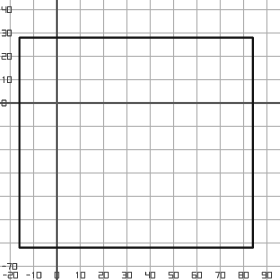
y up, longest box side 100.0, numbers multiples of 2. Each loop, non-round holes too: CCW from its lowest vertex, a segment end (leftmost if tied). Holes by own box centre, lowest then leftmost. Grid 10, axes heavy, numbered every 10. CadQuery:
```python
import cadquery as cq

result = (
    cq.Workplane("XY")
    .moveTo(-16.0, -62.0)
    .lineTo(84.0, -62.0)
    .lineTo(84.0, 28.0)
    .lineTo(-16.0, 28.0)
    .close()
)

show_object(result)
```